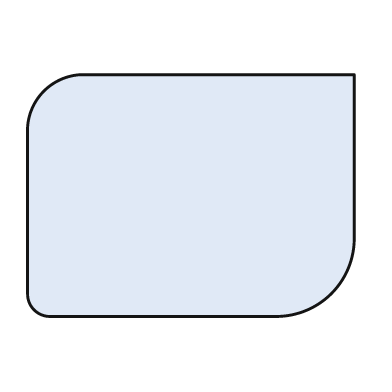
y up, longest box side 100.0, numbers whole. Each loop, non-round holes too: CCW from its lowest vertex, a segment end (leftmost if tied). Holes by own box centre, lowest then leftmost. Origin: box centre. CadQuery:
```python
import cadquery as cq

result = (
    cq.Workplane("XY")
    .moveTo(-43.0, -37.0)
    .lineTo(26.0, -37.0)
    .threePointArc((43.0, -30.0), (50.0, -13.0))
    .lineTo(50.0, 37.0)
    .lineTo(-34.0, 37.0)
    .threePointArc((-45.0, 32.0), (-50.0, 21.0))
    .lineTo(-50.0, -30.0)
    .threePointArc((-48.0, -35.0), (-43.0, -37.0))
    .close()
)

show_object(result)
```